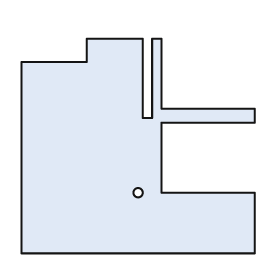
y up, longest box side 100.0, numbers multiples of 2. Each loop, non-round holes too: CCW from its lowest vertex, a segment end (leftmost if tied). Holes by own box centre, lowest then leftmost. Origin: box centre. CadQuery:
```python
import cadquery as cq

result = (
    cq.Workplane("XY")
    .moveTo(-50.0, -46.0)
    .lineTo(50.0, -46.0)
    .lineTo(50.0, -20.0)
    .lineTo(10.0, -20.0)
    .lineTo(10.0, 10.0)
    .lineTo(50.0, 10.0)
    .lineTo(50.0, 16.0)
    .lineTo(10.0, 16.0)
    .lineTo(10.0, 46.0)
    .lineTo(6.0, 46.0)
    .lineTo(6.0, 12.0)
    .lineTo(2.0, 12.0)
    .lineTo(2.0, 46.0)
    .lineTo(-22.0, 46.0)
    .lineTo(-22.0, 36.0)
    .lineTo(-50.0, 36.0)
    .close()
    .moveTo(0.0, -20.0)
    .circle(2.0)
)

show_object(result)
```